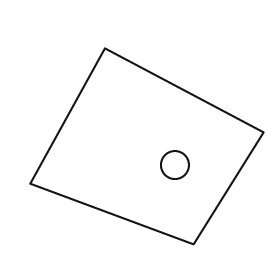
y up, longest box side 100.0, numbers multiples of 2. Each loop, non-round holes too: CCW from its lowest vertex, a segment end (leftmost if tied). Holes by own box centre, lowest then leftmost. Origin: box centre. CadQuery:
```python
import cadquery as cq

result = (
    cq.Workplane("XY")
    .moveTo(20.0, -42.0)
    .lineTo(50.0, 6.0)
    .lineTo(-18.0, 42.0)
    .lineTo(-50.0, -16.0)
    .close()
    .moveTo(12.0, -8.0)
    .circle(6.0)
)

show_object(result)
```